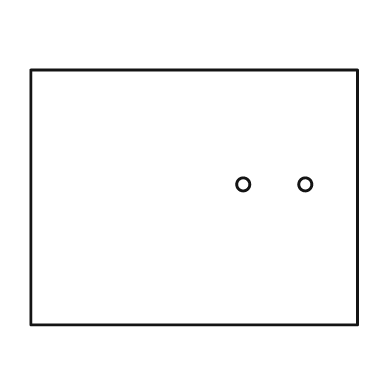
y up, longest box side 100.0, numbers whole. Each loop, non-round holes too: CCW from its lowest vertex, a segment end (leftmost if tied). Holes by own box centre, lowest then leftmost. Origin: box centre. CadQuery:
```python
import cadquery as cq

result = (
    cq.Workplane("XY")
    .moveTo(-50.0, -39.0)
    .lineTo(50.0, -39.0)
    .lineTo(50.0, 39.0)
    .lineTo(-50.0, 39.0)
    .close()
    .moveTo(15.0, 4.0)
    .circle(2.0)
    .moveTo(34.0, 4.0)
    .circle(2.0)
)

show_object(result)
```